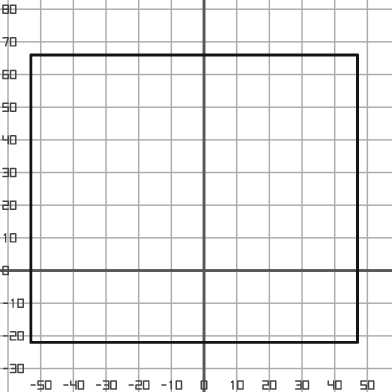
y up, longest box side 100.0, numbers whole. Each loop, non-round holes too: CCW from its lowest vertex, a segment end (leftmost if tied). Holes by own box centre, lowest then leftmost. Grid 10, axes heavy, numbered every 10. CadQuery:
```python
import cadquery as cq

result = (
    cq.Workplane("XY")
    .moveTo(-53.0, -22.0)
    .lineTo(47.0, -22.0)
    .lineTo(47.0, 66.0)
    .lineTo(-53.0, 66.0)
    .close()
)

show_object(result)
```